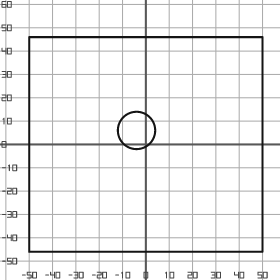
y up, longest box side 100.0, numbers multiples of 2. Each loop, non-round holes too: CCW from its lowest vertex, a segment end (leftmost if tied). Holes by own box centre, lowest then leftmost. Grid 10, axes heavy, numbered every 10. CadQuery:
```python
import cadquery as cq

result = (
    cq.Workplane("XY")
    .moveTo(-50.0, -46.0)
    .lineTo(50.0, -46.0)
    .lineTo(50.0, 46.0)
    .lineTo(-50.0, 46.0)
    .close()
    .moveTo(-4.0, 6.0)
    .circle(8.0)
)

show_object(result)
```